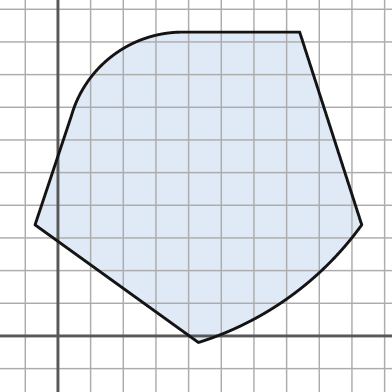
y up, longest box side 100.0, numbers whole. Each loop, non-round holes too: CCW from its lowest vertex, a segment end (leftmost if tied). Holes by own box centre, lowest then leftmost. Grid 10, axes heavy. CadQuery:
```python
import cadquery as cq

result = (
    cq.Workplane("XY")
    .moveTo(43.0, -2.0)
    .threePointArc((71.0, 12.0), (93.0, 34.0))
    .lineTo(74.0, 93.0)
    .lineTo(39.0, 93.0)
    .threePointArc((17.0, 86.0), (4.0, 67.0))
    .lineTo(-7.0, 34.0)
    .close()
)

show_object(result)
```